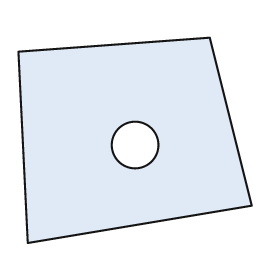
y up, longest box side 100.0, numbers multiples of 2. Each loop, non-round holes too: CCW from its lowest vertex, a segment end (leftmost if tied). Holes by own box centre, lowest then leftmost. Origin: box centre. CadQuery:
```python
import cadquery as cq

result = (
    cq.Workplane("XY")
    .moveTo(-46.0, -44.0)
    .lineTo(50.0, -28.0)
    .lineTo(32.0, 44.0)
    .lineTo(-50.0, 38.0)
    .close()
    .moveTo(0.0, -2.0)
    .circle(10.0)
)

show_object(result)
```